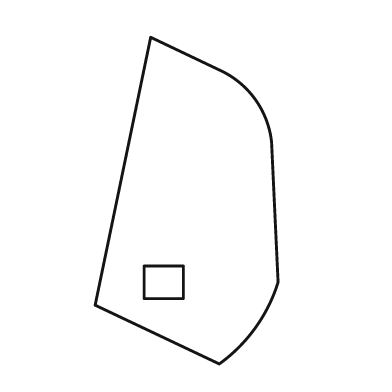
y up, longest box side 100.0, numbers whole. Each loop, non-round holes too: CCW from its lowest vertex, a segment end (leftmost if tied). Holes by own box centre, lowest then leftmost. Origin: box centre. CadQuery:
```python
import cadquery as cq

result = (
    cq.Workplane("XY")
    .moveTo(10.0, -50.0)
    .threePointArc((21.0, -39.0), (28.0, -25.0))
    .lineTo(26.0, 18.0)
    .threePointArc((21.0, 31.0), (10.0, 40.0))
    .lineTo(-11.0, 50.0)
    .lineTo(-28.0, -32.0)
    .close()
    .moveTo(-13.0, -30.0)
    .lineTo(-1.0, -30.0)
    .lineTo(-1.0, -20.0)
    .lineTo(-13.0, -20.0)
    .close()
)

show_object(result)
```